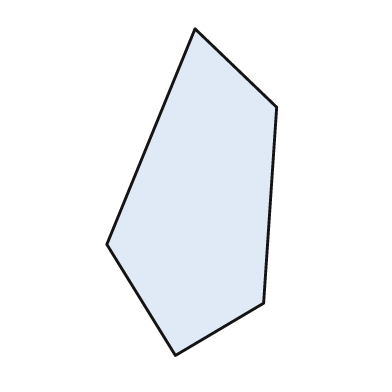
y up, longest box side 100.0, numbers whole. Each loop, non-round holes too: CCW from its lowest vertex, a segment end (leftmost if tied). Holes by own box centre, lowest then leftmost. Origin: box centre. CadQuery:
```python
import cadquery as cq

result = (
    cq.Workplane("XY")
    .moveTo(-5.0, -50.0)
    .lineTo(22.0, -34.0)
    .lineTo(26.0, 26.0)
    .lineTo(1.0, 50.0)
    .lineTo(-26.0, -16.0)
    .close()
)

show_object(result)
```